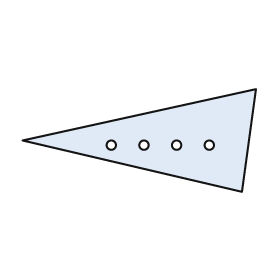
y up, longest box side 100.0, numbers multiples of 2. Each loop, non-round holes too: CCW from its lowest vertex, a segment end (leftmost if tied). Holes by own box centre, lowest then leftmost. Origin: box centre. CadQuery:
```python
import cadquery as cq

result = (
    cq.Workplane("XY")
    .moveTo(44.0, -22.0)
    .lineTo(50.0, 22.0)
    .lineTo(-50.0, 0.0)
    .close()
    .moveTo(-12.0, -2.0)
    .circle(2.0)
    .moveTo(2.0, -2.0)
    .circle(2.0)
    .moveTo(16.0, -2.0)
    .circle(2.0)
    .moveTo(30.0, -2.0)
    .circle(2.0)
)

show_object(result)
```